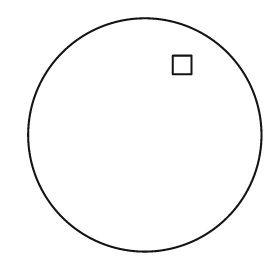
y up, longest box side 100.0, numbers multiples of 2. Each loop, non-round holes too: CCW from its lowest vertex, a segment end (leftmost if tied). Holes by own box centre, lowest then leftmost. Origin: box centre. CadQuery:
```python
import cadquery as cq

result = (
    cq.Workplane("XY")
    .moveTo(0.0, 0.0)
    .circle(50.0)
    .moveTo(12.0, 26.0)
    .lineTo(20.0, 26.0)
    .lineTo(20.0, 34.0)
    .lineTo(12.0, 34.0)
    .close()
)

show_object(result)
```